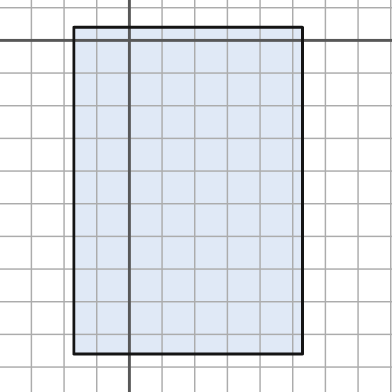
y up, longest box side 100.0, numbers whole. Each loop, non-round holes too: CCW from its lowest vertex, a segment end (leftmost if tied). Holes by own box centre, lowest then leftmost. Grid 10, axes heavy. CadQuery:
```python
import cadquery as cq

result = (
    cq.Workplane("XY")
    .moveTo(-17.0, -96.0)
    .lineTo(53.0, -96.0)
    .lineTo(53.0, 4.0)
    .lineTo(-17.0, 4.0)
    .close()
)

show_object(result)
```